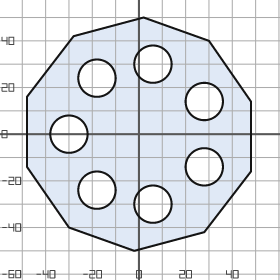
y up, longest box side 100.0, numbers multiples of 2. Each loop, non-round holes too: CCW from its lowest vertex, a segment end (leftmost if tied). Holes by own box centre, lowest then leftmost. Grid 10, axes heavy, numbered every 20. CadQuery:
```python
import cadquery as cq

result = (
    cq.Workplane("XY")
    .moveTo(-2.0, -50.0)
    .lineTo(28.0, -42.0)
    .lineTo(48.0, -16.0)
    .lineTo(48.0, 14.0)
    .lineTo(30.0, 40.0)
    .lineTo(2.0, 50.0)
    .lineTo(-28.0, 42.0)
    .lineTo(-48.0, 16.0)
    .lineTo(-48.0, -14.0)
    .lineTo(-30.0, -40.0)
    .close()
    .moveTo(6.0, -30.0)
    .circle(8.0)
    .moveTo(-18.0, -24.0)
    .circle(8.0)
    .moveTo(28.0, -14.0)
    .circle(8.0)
    .moveTo(-30.0, 0.0)
    .circle(8.0)
    .moveTo(28.0, 14.0)
    .circle(8.0)
    .moveTo(-18.0, 24.0)
    .circle(8.0)
    .moveTo(6.0, 30.0)
    .circle(8.0)
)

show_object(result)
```